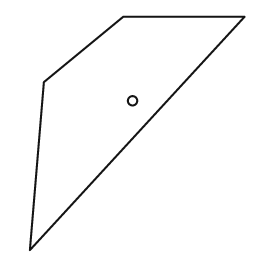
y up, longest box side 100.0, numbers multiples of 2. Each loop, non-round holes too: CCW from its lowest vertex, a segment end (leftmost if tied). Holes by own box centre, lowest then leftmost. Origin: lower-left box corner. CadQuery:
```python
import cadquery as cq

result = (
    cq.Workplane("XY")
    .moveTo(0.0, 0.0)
    .lineTo(92.0, 100.0)
    .lineTo(40.0, 100.0)
    .lineTo(6.0, 72.0)
    .close()
    .moveTo(44.0, 64.0)
    .circle(2.0)
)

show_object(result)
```